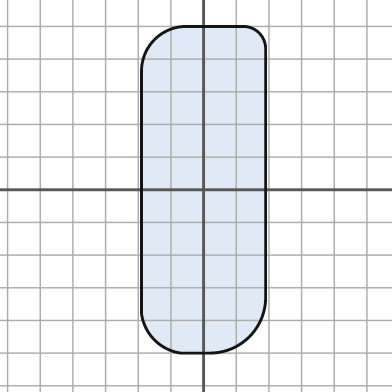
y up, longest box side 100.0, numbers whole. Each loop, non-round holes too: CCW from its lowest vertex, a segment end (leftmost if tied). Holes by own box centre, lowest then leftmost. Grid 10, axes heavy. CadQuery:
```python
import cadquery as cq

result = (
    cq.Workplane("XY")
    .moveTo(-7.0, -50.0)
    .lineTo(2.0, -50.0)
    .threePointArc((14.0, -45.0), (19.0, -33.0))
    .lineTo(19.0, 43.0)
    .threePointArc((17.0, 48.0), (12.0, 50.0))
    .lineTo(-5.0, 50.0)
    .threePointArc((-15.0, 46.0), (-19.0, 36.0))
    .lineTo(-19.0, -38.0)
    .threePointArc((-15.0, -46.0), (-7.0, -50.0))
    .close()
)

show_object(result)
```